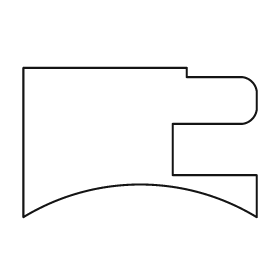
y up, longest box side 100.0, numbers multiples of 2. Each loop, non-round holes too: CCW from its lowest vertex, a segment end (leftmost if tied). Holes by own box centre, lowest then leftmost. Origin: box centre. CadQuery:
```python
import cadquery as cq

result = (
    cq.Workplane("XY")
    .moveTo(-50.0, -32.0)
    .threePointArc((0.0, -18.0), (50.0, -32.0))
    .lineTo(50.0, -14.0)
    .lineTo(14.0, -14.0)
    .lineTo(14.0, 8.0)
    .lineTo(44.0, 8.0)
    .threePointArc((48.0, 10.0), (50.0, 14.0))
    .lineTo(50.0, 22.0)
    .threePointArc((48.0, 26.0), (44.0, 28.0))
    .lineTo(20.0, 28.0)
    .lineTo(20.0, 32.0)
    .lineTo(-50.0, 32.0)
    .close()
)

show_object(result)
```